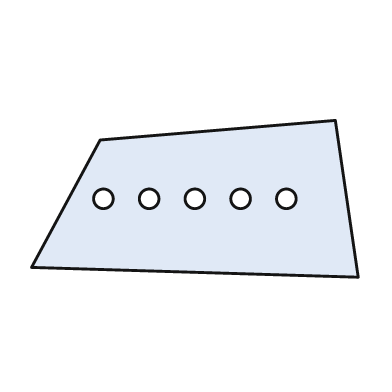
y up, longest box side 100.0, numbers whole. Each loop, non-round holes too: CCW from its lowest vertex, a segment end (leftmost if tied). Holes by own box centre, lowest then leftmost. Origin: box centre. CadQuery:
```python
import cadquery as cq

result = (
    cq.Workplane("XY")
    .moveTo(50.0, -24.0)
    .lineTo(43.0, 24.0)
    .lineTo(-29.0, 18.0)
    .lineTo(-50.0, -21.0)
    .close()
    .moveTo(-28.0, 0.0)
    .circle(3.0)
    .moveTo(-14.0, 0.0)
    .circle(3.0)
    .moveTo(0.0, 0.0)
    .circle(3.0)
    .moveTo(14.0, 0.0)
    .circle(3.0)
    .moveTo(28.0, 0.0)
    .circle(3.0)
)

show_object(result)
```